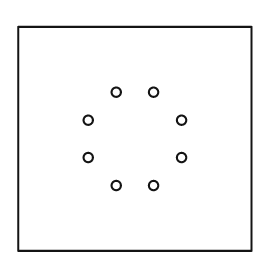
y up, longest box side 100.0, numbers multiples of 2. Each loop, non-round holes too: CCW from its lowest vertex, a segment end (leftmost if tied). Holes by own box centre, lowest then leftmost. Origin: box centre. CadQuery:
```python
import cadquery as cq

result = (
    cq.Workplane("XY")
    .moveTo(-50.0, -48.0)
    .lineTo(50.0, -48.0)
    .lineTo(50.0, 48.0)
    .lineTo(-50.0, 48.0)
    .close()
    .moveTo(-8.0, -20.0)
    .circle(2.0)
    .moveTo(8.0, -20.0)
    .circle(2.0)
    .moveTo(-20.0, -8.0)
    .circle(2.0)
    .moveTo(20.0, -8.0)
    .circle(2.0)
    .moveTo(-20.0, 8.0)
    .circle(2.0)
    .moveTo(20.0, 8.0)
    .circle(2.0)
    .moveTo(-8.0, 20.0)
    .circle(2.0)
    .moveTo(8.0, 20.0)
    .circle(2.0)
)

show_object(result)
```